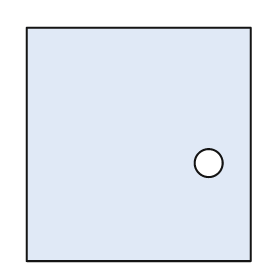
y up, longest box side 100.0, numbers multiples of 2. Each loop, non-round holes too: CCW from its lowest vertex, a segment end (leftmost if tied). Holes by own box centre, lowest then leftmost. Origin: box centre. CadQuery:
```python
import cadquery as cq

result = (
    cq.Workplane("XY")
    .moveTo(-48.0, -50.0)
    .lineTo(48.0, -50.0)
    .lineTo(48.0, 50.0)
    .lineTo(-48.0, 50.0)
    .close()
    .moveTo(30.0, -8.0)
    .circle(6.0)
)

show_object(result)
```